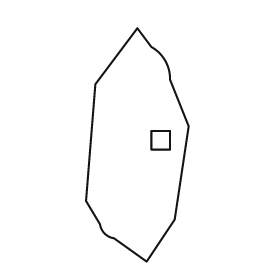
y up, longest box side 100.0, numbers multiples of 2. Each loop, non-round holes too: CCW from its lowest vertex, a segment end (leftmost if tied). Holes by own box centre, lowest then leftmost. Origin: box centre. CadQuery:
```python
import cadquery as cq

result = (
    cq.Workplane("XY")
    .moveTo(4.0, -50.0)
    .lineTo(16.0, -32.0)
    .lineTo(22.0, 8.0)
    .lineTo(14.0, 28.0)
    .threePointArc((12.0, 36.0), (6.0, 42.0))
    .lineTo(0.0, 50.0)
    .lineTo(-18.0, 26.0)
    .lineTo(-22.0, -24.0)
    .lineTo(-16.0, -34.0)
    .threePointArc((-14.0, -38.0), (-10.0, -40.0))
    .close()
    .moveTo(6.0, -2.0)
    .lineTo(14.0, -2.0)
    .lineTo(14.0, 6.0)
    .lineTo(6.0, 6.0)
    .close()
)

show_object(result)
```